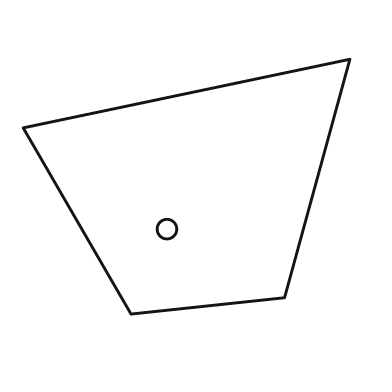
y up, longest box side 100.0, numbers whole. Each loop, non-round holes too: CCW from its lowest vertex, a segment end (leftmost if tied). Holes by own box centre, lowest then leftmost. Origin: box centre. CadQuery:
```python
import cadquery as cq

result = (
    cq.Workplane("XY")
    .moveTo(-17.0, -39.0)
    .lineTo(30.0, -34.0)
    .lineTo(50.0, 39.0)
    .lineTo(-50.0, 18.0)
    .close()
    .moveTo(-6.0, -13.0)
    .circle(3.0)
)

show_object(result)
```